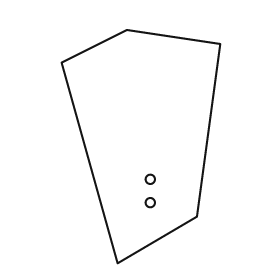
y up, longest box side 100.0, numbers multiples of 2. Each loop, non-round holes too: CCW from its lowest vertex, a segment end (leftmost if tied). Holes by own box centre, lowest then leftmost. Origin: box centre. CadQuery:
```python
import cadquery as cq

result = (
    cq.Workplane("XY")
    .moveTo(-10.0, -50.0)
    .lineTo(24.0, -30.0)
    .lineTo(34.0, 44.0)
    .lineTo(-6.0, 50.0)
    .lineTo(-34.0, 36.0)
    .close()
    .moveTo(4.0, -24.0)
    .circle(2.0)
    .moveTo(4.0, -14.0)
    .circle(2.0)
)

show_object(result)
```